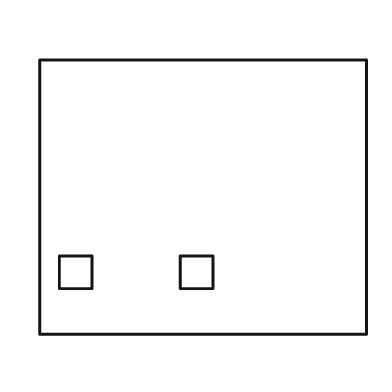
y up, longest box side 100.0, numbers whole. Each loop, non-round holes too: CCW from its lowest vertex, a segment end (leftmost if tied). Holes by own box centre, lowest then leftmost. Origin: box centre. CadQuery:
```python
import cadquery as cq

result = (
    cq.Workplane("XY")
    .moveTo(-50.0, -42.0)
    .lineTo(50.0, -42.0)
    .lineTo(50.0, 42.0)
    .lineTo(-50.0, 42.0)
    .close()
    .moveTo(-44.0, -28.0)
    .lineTo(-34.0, -28.0)
    .lineTo(-34.0, -18.0)
    .lineTo(-44.0, -18.0)
    .close()
    .moveTo(-7.0, -28.0)
    .lineTo(3.0, -28.0)
    .lineTo(3.0, -18.0)
    .lineTo(-7.0, -18.0)
    .close()
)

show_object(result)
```